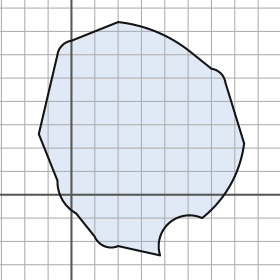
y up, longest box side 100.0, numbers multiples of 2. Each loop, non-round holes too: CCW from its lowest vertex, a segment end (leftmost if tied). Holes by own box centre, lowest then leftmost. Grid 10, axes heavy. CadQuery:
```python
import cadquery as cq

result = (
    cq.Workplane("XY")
    .moveTo(38.0, -26.0)
    .threePointArc((42.0, -12.0), (56.0, -10.0))
    .threePointArc((68.0, 4.0), (74.0, 22.0))
    .lineTo(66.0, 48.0)
    .threePointArc((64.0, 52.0), (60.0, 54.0))
    .lineTo(50.0, 62.0)
    .threePointArc((36.0, 70.0), (20.0, 74.0))
    .lineTo(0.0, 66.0)
    .threePointArc((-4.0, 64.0), (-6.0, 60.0))
    .lineTo(-14.0, 26.0)
    .lineTo(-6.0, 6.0)
    .threePointArc((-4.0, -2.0), (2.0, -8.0))
    .lineTo(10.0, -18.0)
    .threePointArc((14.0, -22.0), (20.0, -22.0))
    .close()
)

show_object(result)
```